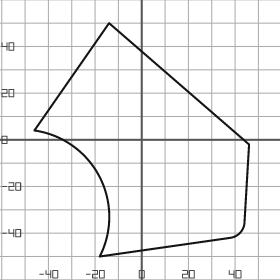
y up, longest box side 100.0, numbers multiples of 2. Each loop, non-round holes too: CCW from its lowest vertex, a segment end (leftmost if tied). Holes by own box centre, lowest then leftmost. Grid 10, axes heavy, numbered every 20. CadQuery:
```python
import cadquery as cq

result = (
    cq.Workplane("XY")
    .moveTo(-18.0, -50.0)
    .lineTo(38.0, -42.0)
    .threePointArc((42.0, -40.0), (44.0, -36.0))
    .lineTo(46.0, -2.0)
    .lineTo(-14.0, 50.0)
    .lineTo(-46.0, 4.0)
    .threePointArc((-18.0, -16.0), (-18.0, -50.0))
    .close()
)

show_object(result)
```